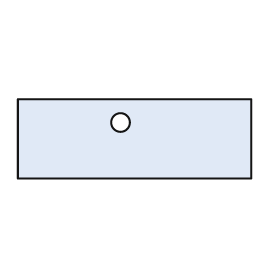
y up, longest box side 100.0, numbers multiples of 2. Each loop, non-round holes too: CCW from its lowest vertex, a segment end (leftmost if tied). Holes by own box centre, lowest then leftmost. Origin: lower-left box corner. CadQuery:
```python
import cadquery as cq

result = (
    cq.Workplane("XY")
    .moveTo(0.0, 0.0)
    .lineTo(100.0, 0.0)
    .lineTo(100.0, 34.0)
    .lineTo(0.0, 34.0)
    .close()
    .moveTo(44.0, 24.0)
    .circle(4.0)
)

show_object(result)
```